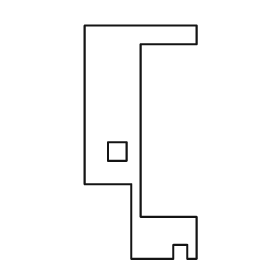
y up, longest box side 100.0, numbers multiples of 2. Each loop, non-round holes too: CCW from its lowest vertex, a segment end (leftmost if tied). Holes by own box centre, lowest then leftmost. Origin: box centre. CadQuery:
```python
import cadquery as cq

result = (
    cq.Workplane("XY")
    .moveTo(-4.0, -50.0)
    .lineTo(14.0, -50.0)
    .lineTo(14.0, -44.0)
    .lineTo(20.0, -44.0)
    .lineTo(20.0, -50.0)
    .lineTo(24.0, -50.0)
    .lineTo(24.0, -32.0)
    .lineTo(0.0, -32.0)
    .lineTo(0.0, 42.0)
    .lineTo(24.0, 42.0)
    .lineTo(24.0, 50.0)
    .lineTo(-24.0, 50.0)
    .lineTo(-24.0, -18.0)
    .lineTo(-4.0, -18.0)
    .close()
    .moveTo(-14.0, -8.0)
    .lineTo(-6.0, -8.0)
    .lineTo(-6.0, 0.0)
    .lineTo(-14.0, 0.0)
    .close()
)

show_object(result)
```